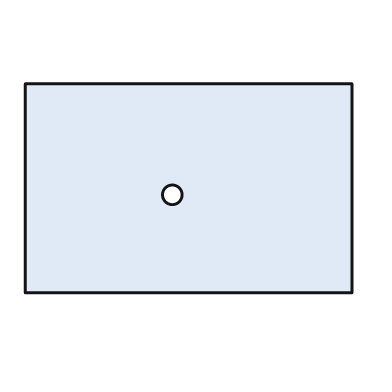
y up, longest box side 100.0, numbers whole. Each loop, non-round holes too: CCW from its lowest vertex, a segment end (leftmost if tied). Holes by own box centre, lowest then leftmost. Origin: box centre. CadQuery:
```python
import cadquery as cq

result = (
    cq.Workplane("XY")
    .moveTo(-50.0, -32.0)
    .lineTo(50.0, -32.0)
    .lineTo(50.0, 32.0)
    .lineTo(-50.0, 32.0)
    .close()
    .moveTo(-5.0, -2.0)
    .circle(3.0)
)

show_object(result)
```